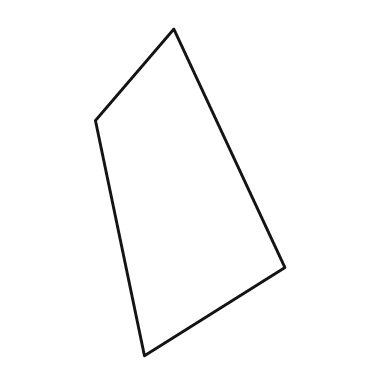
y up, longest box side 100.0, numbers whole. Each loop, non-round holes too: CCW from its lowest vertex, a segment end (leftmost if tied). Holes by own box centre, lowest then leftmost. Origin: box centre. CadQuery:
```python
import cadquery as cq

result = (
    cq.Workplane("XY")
    .moveTo(-14.0, -50.0)
    .lineTo(29.0, -23.0)
    .lineTo(-5.0, 50.0)
    .lineTo(-29.0, 22.0)
    .close()
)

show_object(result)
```